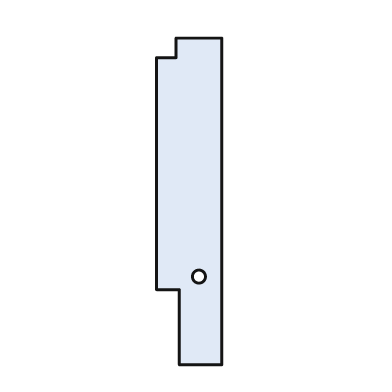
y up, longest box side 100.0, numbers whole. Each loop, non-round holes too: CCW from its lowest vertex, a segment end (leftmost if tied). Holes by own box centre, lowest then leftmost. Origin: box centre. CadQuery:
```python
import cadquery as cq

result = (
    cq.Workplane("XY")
    .moveTo(-3.0, -50.0)
    .lineTo(10.0, -50.0)
    .lineTo(10.0, 50.0)
    .lineTo(-4.0, 50.0)
    .lineTo(-4.0, 44.0)
    .lineTo(-10.0, 44.0)
    .lineTo(-10.0, -27.0)
    .lineTo(-3.0, -27.0)
    .close()
    .moveTo(3.0, -23.0)
    .circle(2.0)
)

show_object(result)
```